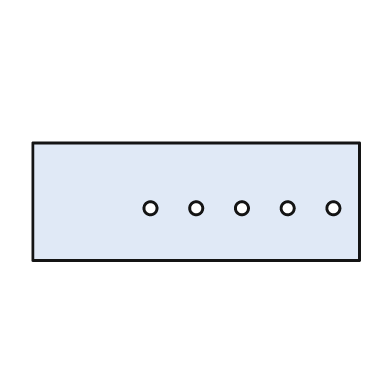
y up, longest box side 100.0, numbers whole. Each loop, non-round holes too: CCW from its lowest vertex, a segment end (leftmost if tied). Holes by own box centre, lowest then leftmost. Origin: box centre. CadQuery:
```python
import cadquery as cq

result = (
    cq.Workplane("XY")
    .moveTo(-50.0, -18.0)
    .lineTo(50.0, -18.0)
    .lineTo(50.0, 18.0)
    .lineTo(-50.0, 18.0)
    .close()
    .moveTo(-14.0, -2.0)
    .circle(2.0)
    .moveTo(0.0, -2.0)
    .circle(2.0)
    .moveTo(14.0, -2.0)
    .circle(2.0)
    .moveTo(28.0, -2.0)
    .circle(2.0)
    .moveTo(42.0, -2.0)
    .circle(2.0)
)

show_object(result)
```